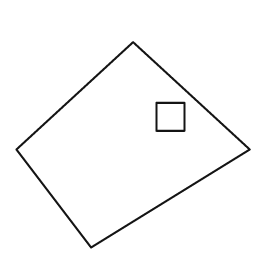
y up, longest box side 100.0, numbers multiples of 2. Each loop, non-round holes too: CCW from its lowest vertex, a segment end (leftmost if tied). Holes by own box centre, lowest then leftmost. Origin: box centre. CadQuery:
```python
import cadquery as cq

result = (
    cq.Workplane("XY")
    .moveTo(-18.0, -44.0)
    .lineTo(50.0, -2.0)
    .lineTo(0.0, 44.0)
    .lineTo(-50.0, -2.0)
    .close()
    .moveTo(10.0, 6.0)
    .lineTo(22.0, 6.0)
    .lineTo(22.0, 18.0)
    .lineTo(10.0, 18.0)
    .close()
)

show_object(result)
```